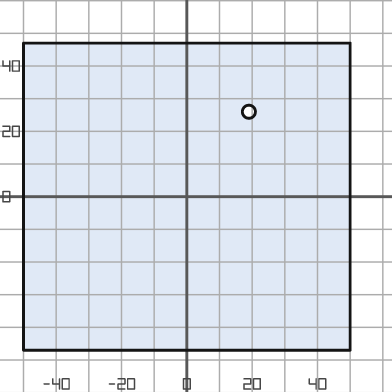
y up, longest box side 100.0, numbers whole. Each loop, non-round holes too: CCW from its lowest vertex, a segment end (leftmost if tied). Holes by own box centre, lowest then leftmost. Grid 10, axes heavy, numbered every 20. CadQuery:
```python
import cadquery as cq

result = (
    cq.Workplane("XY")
    .moveTo(-50.0, -47.0)
    .lineTo(50.0, -47.0)
    .lineTo(50.0, 47.0)
    .lineTo(-50.0, 47.0)
    .close()
    .moveTo(19.0, 26.0)
    .circle(2.0)
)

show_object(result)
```